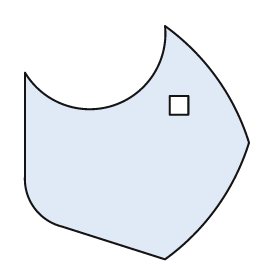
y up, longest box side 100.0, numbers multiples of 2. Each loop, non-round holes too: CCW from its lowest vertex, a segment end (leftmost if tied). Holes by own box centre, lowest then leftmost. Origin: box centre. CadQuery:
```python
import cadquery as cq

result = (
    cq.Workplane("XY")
    .moveTo(12.0, -50.0)
    .threePointArc((34.0, -28.0), (48.0, 0.0))
    .threePointArc((34.0, 28.0), (12.0, 50.0))
    .threePointArc((-10.0, 16.0), (-48.0, 30.0))
    .lineTo(-48.0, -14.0)
    .threePointArc((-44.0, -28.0), (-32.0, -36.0))
    .close()
    .moveTo(14.0, 12.0)
    .lineTo(22.0, 12.0)
    .lineTo(22.0, 20.0)
    .lineTo(14.0, 20.0)
    .close()
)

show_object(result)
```